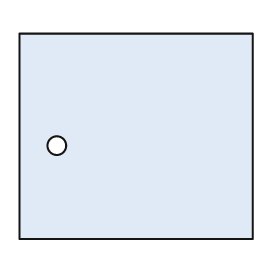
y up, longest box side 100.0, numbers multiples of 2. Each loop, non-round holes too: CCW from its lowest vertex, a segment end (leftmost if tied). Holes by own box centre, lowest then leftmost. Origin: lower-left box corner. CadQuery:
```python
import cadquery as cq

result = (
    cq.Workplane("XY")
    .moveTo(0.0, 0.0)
    .lineTo(100.0, 0.0)
    .lineTo(100.0, 88.0)
    .lineTo(0.0, 88.0)
    .close()
    .moveTo(16.0, 40.0)
    .circle(4.0)
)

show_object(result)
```